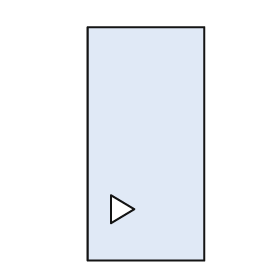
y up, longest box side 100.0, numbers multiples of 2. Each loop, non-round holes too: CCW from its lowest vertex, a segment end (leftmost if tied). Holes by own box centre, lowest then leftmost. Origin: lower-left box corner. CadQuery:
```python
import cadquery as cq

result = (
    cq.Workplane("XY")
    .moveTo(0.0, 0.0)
    .lineTo(50.0, 0.0)
    .lineTo(50.0, 100.0)
    .lineTo(0.0, 100.0)
    .close()
    .moveTo(10.0, 16.0)
    .lineTo(20.0, 22.0)
    .lineTo(10.0, 28.0)
    .close()
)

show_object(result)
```